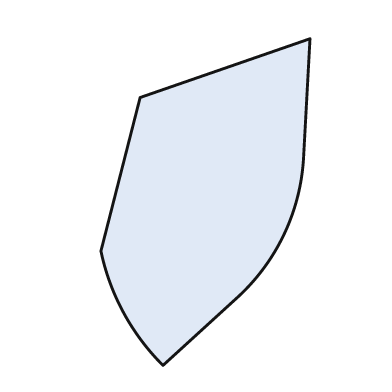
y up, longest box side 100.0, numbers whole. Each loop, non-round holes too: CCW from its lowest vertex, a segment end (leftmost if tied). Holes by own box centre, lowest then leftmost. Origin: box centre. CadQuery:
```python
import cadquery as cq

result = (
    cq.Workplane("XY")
    .moveTo(-13.0, -50.0)
    .lineTo(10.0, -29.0)
    .threePointArc((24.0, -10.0), (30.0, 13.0))
    .lineTo(32.0, 50.0)
    .lineTo(-20.0, 32.0)
    .lineTo(-32.0, -15.0)
    .threePointArc((-25.0, -34.0), (-13.0, -50.0))
    .close()
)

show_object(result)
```